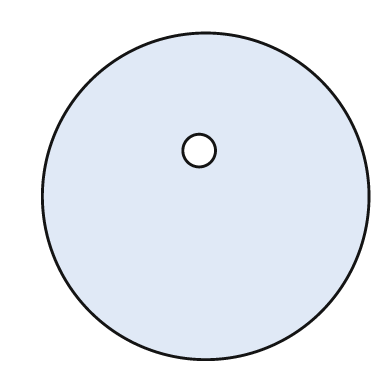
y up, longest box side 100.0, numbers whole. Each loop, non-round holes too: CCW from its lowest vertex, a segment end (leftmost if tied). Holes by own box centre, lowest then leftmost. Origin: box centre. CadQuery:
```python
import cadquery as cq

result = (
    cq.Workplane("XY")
    .moveTo(0.0, 0.0)
    .circle(50.0)
    .moveTo(-2.0, 14.0)
    .circle(5.0)
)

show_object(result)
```